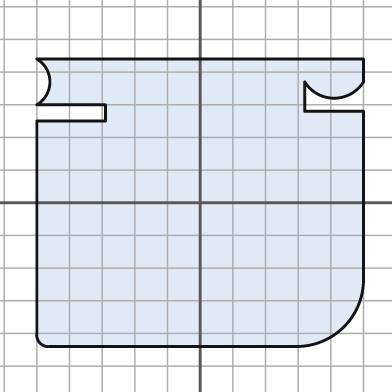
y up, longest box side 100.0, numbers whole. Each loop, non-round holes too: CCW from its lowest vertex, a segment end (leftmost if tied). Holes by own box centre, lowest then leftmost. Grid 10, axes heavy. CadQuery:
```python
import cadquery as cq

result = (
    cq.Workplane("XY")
    .moveTo(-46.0, -44.0)
    .lineTo(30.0, -44.0)
    .threePointArc((44.0, -38.0), (50.0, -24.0))
    .lineTo(50.0, 28.0)
    .lineTo(32.0, 28.0)
    .lineTo(32.0, 37.0)
    .threePointArc((41.0, 32.0), (50.0, 37.0))
    .lineTo(50.0, 44.0)
    .lineTo(-50.0, 44.0)
    .threePointArc((-46.0, 37.0), (-50.0, 30.0))
    .lineTo(-29.0, 30.0)
    .lineTo(-29.0, 25.0)
    .lineTo(-50.0, 25.0)
    .lineTo(-50.0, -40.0)
    .threePointArc((-49.0, -43.0), (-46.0, -44.0))
    .close()
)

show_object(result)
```